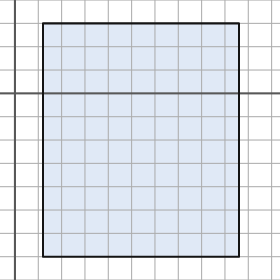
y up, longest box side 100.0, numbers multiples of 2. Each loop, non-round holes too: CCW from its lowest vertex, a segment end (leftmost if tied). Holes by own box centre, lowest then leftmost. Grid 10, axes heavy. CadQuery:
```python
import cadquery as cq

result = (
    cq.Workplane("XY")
    .moveTo(12.0, -70.0)
    .lineTo(96.0, -70.0)
    .lineTo(96.0, 30.0)
    .lineTo(12.0, 30.0)
    .close()
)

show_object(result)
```